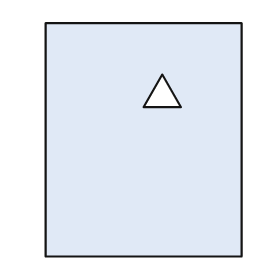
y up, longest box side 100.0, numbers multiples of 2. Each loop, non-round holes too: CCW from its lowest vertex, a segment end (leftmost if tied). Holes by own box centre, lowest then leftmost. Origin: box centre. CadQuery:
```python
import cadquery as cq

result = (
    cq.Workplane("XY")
    .moveTo(-42.0, -50.0)
    .lineTo(42.0, -50.0)
    .lineTo(42.0, 50.0)
    .lineTo(-42.0, 50.0)
    .close()
    .moveTo(0.0, 14.0)
    .lineTo(16.0, 14.0)
    .lineTo(8.0, 28.0)
    .close()
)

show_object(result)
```